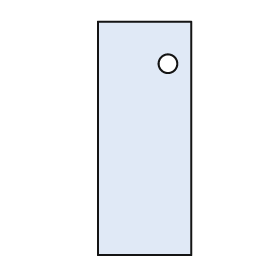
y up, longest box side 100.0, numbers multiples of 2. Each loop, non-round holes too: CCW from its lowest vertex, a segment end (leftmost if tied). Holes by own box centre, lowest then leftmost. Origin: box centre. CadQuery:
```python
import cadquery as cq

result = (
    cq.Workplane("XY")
    .moveTo(-20.0, -50.0)
    .lineTo(20.0, -50.0)
    .lineTo(20.0, 50.0)
    .lineTo(-20.0, 50.0)
    .close()
    .moveTo(10.0, 32.0)
    .circle(4.0)
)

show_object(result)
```